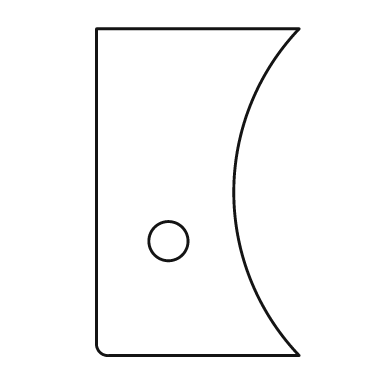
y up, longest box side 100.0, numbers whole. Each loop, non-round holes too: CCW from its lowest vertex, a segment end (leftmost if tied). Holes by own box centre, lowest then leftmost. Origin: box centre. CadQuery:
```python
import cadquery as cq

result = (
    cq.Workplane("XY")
    .moveTo(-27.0, -50.0)
    .lineTo(31.0, -50.0)
    .threePointArc((11.0, 0.0), (31.0, 50.0))
    .lineTo(-31.0, 50.0)
    .lineTo(-31.0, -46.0)
    .threePointArc((-30.0, -49.0), (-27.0, -50.0))
    .close()
    .moveTo(-9.0, -15.0)
    .circle(6.0)
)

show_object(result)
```